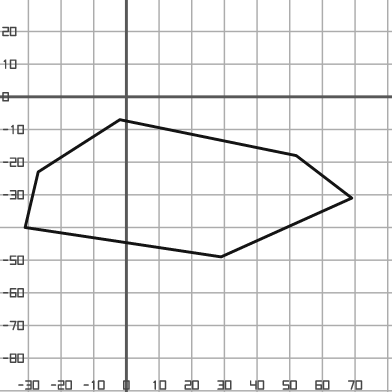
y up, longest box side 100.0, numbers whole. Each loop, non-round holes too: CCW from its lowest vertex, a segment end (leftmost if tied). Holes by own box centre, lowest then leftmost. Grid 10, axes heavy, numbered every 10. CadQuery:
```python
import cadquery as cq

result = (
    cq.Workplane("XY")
    .moveTo(29.0, -49.0)
    .lineTo(69.0, -31.0)
    .lineTo(52.0, -18.0)
    .lineTo(-2.0, -7.0)
    .lineTo(-27.0, -23.0)
    .lineTo(-31.0, -40.0)
    .close()
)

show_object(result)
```